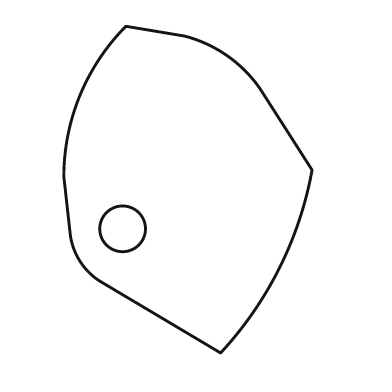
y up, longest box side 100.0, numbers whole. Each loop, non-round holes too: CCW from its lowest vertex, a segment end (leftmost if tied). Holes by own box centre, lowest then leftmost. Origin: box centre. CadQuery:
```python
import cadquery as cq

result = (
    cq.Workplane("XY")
    .moveTo(10.0, -50.0)
    .threePointArc((28.0, -24.0), (38.0, 6.0))
    .lineTo(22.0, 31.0)
    .threePointArc((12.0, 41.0), (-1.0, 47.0))
    .lineTo(-19.0, 50.0)
    .threePointArc((-33.0, 29.0), (-38.0, 4.0))
    .lineTo(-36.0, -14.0)
    .threePointArc((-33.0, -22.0), (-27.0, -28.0))
    .close()
    .moveTo(-20.0, -12.0)
    .circle(7.0)
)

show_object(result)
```